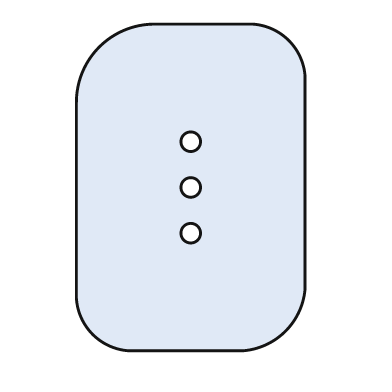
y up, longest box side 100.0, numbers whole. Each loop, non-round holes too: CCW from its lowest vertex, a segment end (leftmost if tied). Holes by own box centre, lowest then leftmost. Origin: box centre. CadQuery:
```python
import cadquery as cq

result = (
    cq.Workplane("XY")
    .moveTo(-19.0, -50.0)
    .lineTo(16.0, -50.0)
    .threePointArc((29.0, -44.0), (35.0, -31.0))
    .lineTo(35.0, 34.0)
    .threePointArc((30.0, 45.0), (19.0, 50.0))
    .lineTo(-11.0, 50.0)
    .threePointArc((-28.0, 43.0), (-35.0, 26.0))
    .lineTo(-35.0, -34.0)
    .threePointArc((-30.0, -45.0), (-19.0, -50.0))
    .close()
    .moveTo(0.0, -14.0)
    .circle(3.0)
    .moveTo(0.0, 0.0)
    .circle(3.0)
    .moveTo(0.0, 14.0)
    .circle(3.0)
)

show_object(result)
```